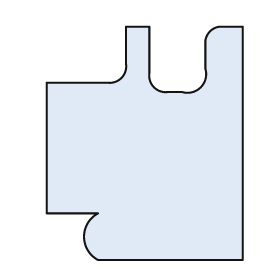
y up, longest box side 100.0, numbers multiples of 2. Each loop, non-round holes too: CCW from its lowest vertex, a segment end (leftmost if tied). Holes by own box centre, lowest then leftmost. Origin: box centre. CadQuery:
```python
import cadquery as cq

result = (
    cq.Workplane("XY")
    .moveTo(-20.0, -50.0)
    .lineTo(42.0, -50.0)
    .lineTo(42.0, 50.0)
    .lineTo(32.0, 50.0)
    .threePointArc((28.0, 48.0), (26.0, 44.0))
    .lineTo(26.0, 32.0)
    .threePointArc((24.0, 24.0), (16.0, 22.0))
    .lineTo(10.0, 22.0)
    .threePointArc((4.0, 24.0), (2.0, 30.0))
    .lineTo(2.0, 50.0)
    .lineTo(-8.0, 50.0)
    .lineTo(-8.0, 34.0)
    .threePointArc((-10.0, 28.0), (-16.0, 26.0))
    .lineTo(-42.0, 26.0)
    .lineTo(-42.0, -30.0)
    .lineTo(-20.0, -30.0)
    .threePointArc((-26.0, -40.0), (-20.0, -50.0))
    .close()
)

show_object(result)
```